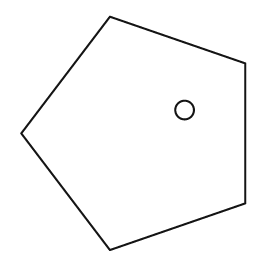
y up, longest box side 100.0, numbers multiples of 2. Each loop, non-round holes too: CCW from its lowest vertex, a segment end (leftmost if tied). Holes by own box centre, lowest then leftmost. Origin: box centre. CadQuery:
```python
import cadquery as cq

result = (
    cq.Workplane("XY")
    .moveTo(-10.0, -50.0)
    .lineTo(48.0, -30.0)
    .lineTo(48.0, 30.0)
    .lineTo(-10.0, 50.0)
    .lineTo(-48.0, 0.0)
    .close()
    .moveTo(22.0, 10.0)
    .circle(4.0)
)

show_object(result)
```